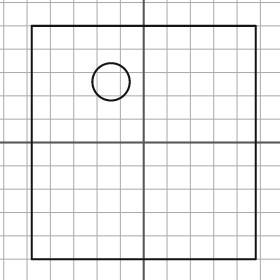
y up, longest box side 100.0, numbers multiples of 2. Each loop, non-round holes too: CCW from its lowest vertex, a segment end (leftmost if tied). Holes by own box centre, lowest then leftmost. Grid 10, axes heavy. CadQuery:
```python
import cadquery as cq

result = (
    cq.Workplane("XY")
    .moveTo(-48.0, -50.0)
    .lineTo(48.0, -50.0)
    .lineTo(48.0, 50.0)
    .lineTo(-48.0, 50.0)
    .close()
    .moveTo(-14.0, 26.0)
    .circle(8.0)
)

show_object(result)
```